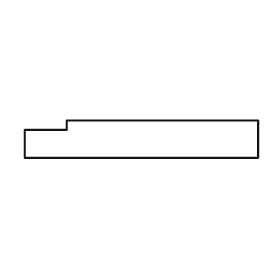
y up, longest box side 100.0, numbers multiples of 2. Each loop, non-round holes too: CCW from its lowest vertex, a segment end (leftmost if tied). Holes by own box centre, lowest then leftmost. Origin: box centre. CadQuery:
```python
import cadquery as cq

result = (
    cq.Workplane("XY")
    .moveTo(-50.0, -8.0)
    .lineTo(50.0, -8.0)
    .lineTo(50.0, 8.0)
    .lineTo(-32.0, 8.0)
    .lineTo(-32.0, 4.0)
    .lineTo(-50.0, 4.0)
    .close()
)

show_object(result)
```